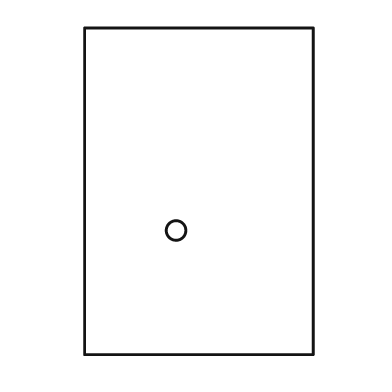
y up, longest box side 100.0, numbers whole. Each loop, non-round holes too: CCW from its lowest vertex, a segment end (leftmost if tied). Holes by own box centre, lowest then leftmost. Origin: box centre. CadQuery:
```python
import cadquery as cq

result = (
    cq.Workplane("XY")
    .moveTo(-35.0, -50.0)
    .lineTo(35.0, -50.0)
    .lineTo(35.0, 50.0)
    .lineTo(-35.0, 50.0)
    .close()
    .moveTo(-7.0, -12.0)
    .circle(3.0)
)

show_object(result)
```